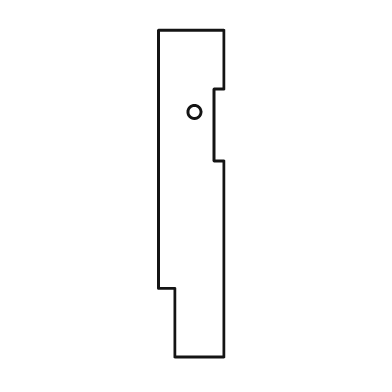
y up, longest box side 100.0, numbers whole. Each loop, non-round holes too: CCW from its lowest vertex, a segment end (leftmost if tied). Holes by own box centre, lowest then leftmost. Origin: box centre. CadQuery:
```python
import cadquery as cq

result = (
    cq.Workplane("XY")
    .moveTo(-5.0, -50.0)
    .lineTo(10.0, -50.0)
    .lineTo(10.0, 10.0)
    .lineTo(7.0, 10.0)
    .lineTo(7.0, 32.0)
    .lineTo(10.0, 32.0)
    .lineTo(10.0, 50.0)
    .lineTo(-10.0, 50.0)
    .lineTo(-10.0, -29.0)
    .lineTo(-5.0, -29.0)
    .close()
    .moveTo(1.0, 25.0)
    .circle(2.0)
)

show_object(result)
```